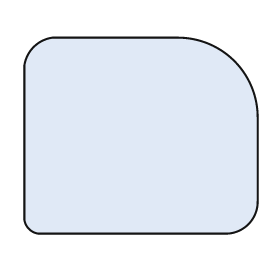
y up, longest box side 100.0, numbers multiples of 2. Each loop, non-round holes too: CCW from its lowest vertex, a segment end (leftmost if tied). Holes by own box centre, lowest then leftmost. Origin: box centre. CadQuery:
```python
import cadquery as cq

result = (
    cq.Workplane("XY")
    .moveTo(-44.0, -42.0)
    .lineTo(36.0, -42.0)
    .threePointArc((46.0, -38.0), (50.0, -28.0))
    .lineTo(50.0, 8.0)
    .threePointArc((40.0, 32.0), (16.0, 42.0))
    .lineTo(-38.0, 42.0)
    .threePointArc((-46.0, 38.0), (-50.0, 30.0))
    .lineTo(-50.0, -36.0)
    .threePointArc((-48.0, -40.0), (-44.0, -42.0))
    .close()
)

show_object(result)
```